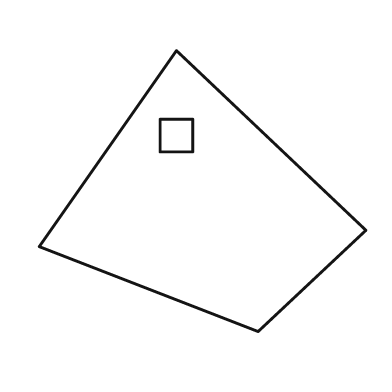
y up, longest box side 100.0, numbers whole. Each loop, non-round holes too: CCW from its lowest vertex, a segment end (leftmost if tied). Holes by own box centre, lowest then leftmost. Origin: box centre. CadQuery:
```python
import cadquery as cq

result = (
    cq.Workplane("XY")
    .moveTo(17.0, -43.0)
    .lineTo(50.0, -12.0)
    .lineTo(-8.0, 43.0)
    .lineTo(-50.0, -17.0)
    .close()
    .moveTo(-13.0, 12.0)
    .lineTo(-3.0, 12.0)
    .lineTo(-3.0, 22.0)
    .lineTo(-13.0, 22.0)
    .close()
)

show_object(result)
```